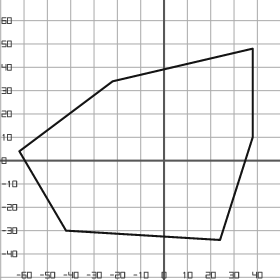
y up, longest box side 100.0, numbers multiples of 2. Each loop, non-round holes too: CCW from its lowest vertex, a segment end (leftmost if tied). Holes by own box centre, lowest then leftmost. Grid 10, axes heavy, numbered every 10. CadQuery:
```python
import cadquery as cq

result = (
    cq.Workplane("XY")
    .moveTo(24.0, -34.0)
    .lineTo(38.0, 10.0)
    .lineTo(38.0, 48.0)
    .lineTo(-22.0, 34.0)
    .lineTo(-62.0, 4.0)
    .lineTo(-42.0, -30.0)
    .close()
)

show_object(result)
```